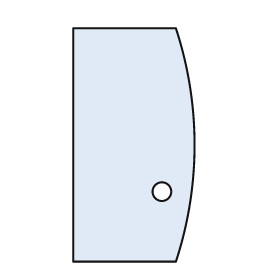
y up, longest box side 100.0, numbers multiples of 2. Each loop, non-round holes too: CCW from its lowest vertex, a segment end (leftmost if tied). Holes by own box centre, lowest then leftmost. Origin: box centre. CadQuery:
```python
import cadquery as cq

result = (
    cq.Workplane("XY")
    .moveTo(-26.0, -50.0)
    .lineTo(18.0, -50.0)
    .threePointArc((26.0, 0.0), (18.0, 50.0))
    .lineTo(-26.0, 50.0)
    .close()
    .moveTo(12.0, -20.0)
    .circle(4.0)
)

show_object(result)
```